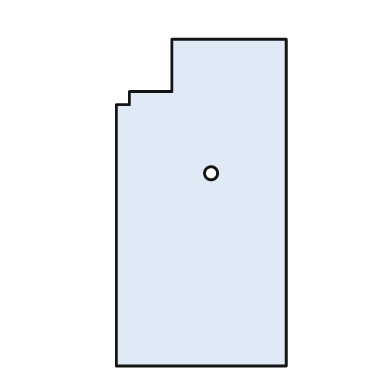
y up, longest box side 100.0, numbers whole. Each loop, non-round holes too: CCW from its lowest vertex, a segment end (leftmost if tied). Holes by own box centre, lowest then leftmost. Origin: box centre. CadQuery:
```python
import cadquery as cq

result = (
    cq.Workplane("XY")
    .moveTo(-26.0, -50.0)
    .lineTo(26.0, -50.0)
    .lineTo(26.0, 50.0)
    .lineTo(-9.0, 50.0)
    .lineTo(-9.0, 34.0)
    .lineTo(-22.0, 34.0)
    .lineTo(-22.0, 30.0)
    .lineTo(-26.0, 30.0)
    .close()
    .moveTo(3.0, 9.0)
    .circle(2.0)
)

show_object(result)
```